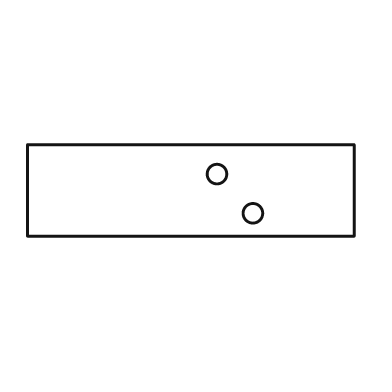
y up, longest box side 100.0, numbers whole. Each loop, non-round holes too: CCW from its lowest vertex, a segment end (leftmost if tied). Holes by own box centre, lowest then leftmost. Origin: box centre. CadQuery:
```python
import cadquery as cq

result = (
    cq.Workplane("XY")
    .moveTo(-50.0, -14.0)
    .lineTo(50.0, -14.0)
    .lineTo(50.0, 14.0)
    .lineTo(-50.0, 14.0)
    .close()
    .moveTo(19.0, -7.0)
    .circle(3.0)
    .moveTo(8.0, 5.0)
    .circle(3.0)
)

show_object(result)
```